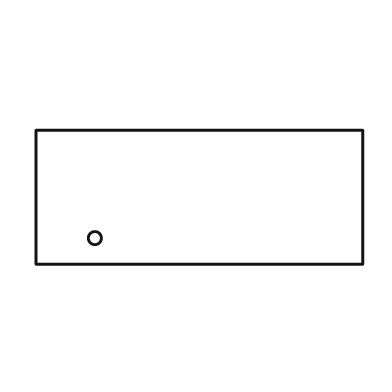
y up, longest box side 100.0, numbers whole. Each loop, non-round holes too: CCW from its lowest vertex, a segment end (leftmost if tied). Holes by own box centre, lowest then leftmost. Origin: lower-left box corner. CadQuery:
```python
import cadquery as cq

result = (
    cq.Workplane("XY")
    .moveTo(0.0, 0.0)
    .lineTo(100.0, 0.0)
    .lineTo(100.0, 41.0)
    .lineTo(0.0, 41.0)
    .close()
    .moveTo(18.0, 8.0)
    .circle(2.0)
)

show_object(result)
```